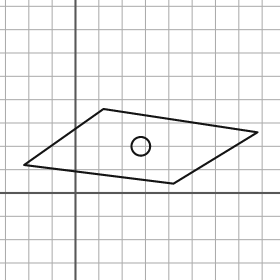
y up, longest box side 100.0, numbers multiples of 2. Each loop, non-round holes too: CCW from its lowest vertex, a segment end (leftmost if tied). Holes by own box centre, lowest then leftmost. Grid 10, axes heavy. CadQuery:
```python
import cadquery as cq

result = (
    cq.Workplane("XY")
    .moveTo(42.0, 4.0)
    .lineTo(78.0, 26.0)
    .lineTo(12.0, 36.0)
    .lineTo(-22.0, 12.0)
    .close()
    .moveTo(28.0, 20.0)
    .circle(4.0)
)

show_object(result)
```